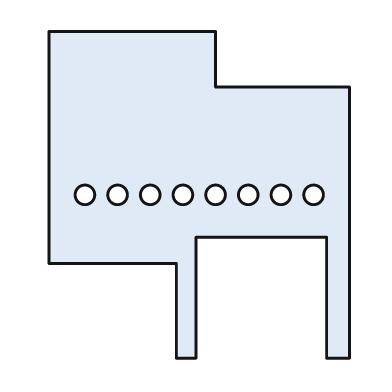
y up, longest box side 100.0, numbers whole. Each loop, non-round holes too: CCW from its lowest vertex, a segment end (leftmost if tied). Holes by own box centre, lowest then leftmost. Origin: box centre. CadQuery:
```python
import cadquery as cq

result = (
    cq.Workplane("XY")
    .moveTo(-7.0, -50.0)
    .lineTo(-1.0, -50.0)
    .lineTo(-1.0, -13.0)
    .lineTo(39.0, -13.0)
    .lineTo(39.0, -50.0)
    .lineTo(46.0, -50.0)
    .lineTo(46.0, 33.0)
    .lineTo(5.0, 33.0)
    .lineTo(5.0, 50.0)
    .lineTo(-46.0, 50.0)
    .lineTo(-46.0, -21.0)
    .lineTo(-7.0, -21.0)
    .close()
    .moveTo(-35.0, 0.0)
    .circle(3.0)
    .moveTo(-25.0, 0.0)
    .circle(3.0)
    .moveTo(-15.0, 0.0)
    .circle(3.0)
    .moveTo(-5.0, 0.0)
    .circle(3.0)
    .moveTo(5.0, 0.0)
    .circle(3.0)
    .moveTo(15.0, 0.0)
    .circle(3.0)
    .moveTo(25.0, 0.0)
    .circle(3.0)
    .moveTo(35.0, 0.0)
    .circle(3.0)
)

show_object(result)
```